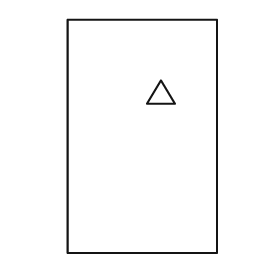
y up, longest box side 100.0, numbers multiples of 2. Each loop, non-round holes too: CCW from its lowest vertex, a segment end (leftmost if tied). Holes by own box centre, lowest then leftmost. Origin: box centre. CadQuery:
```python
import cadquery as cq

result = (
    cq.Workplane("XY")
    .moveTo(-32.0, -50.0)
    .lineTo(32.0, -50.0)
    .lineTo(32.0, 50.0)
    .lineTo(-32.0, 50.0)
    .close()
    .moveTo(2.0, 14.0)
    .lineTo(14.0, 14.0)
    .lineTo(8.0, 24.0)
    .close()
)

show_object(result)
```